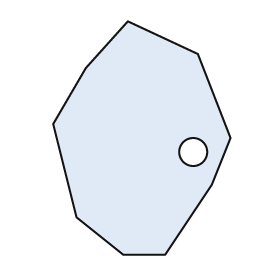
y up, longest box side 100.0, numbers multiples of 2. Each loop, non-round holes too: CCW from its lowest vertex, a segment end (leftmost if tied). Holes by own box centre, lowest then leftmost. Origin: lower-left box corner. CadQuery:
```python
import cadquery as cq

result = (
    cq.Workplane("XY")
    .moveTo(30.0, 0.0)
    .lineTo(48.0, 0.0)
    .lineTo(68.0, 30.0)
    .lineTo(76.0, 50.0)
    .lineTo(62.0, 86.0)
    .lineTo(32.0, 100.0)
    .lineTo(14.0, 80.0)
    .lineTo(0.0, 56.0)
    .lineTo(10.0, 16.0)
    .close()
    .moveTo(60.0, 44.0)
    .circle(6.0)
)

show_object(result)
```